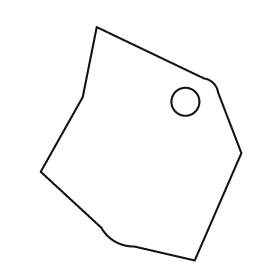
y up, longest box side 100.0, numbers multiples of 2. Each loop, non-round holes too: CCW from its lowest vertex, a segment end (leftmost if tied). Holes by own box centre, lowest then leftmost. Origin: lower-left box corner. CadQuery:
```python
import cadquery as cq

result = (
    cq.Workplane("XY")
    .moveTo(66.0, 0.0)
    .lineTo(86.0, 46.0)
    .lineTo(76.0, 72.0)
    .threePointArc((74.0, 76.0), (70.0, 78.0))
    .lineTo(24.0, 100.0)
    .lineTo(18.0, 70.0)
    .lineTo(0.0, 38.0)
    .lineTo(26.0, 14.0)
    .threePointArc((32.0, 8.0), (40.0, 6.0))
    .close()
    .moveTo(62.0, 68.0)
    .circle(6.0)
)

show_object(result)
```